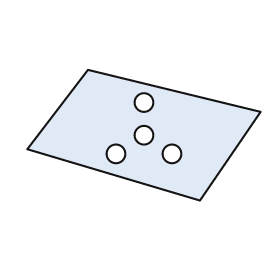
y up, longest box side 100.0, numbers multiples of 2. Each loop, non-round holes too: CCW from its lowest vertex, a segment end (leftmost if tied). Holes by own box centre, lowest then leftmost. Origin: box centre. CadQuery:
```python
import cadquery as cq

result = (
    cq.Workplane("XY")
    .moveTo(24.0, -28.0)
    .lineTo(50.0, 10.0)
    .lineTo(-24.0, 28.0)
    .lineTo(-50.0, -6.0)
    .close()
    .moveTo(-12.0, -8.0)
    .circle(4.0)
    .moveTo(12.0, -8.0)
    .circle(4.0)
    .moveTo(0.0, 0.0)
    .circle(4.0)
    .moveTo(0.0, 14.0)
    .circle(4.0)
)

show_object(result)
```